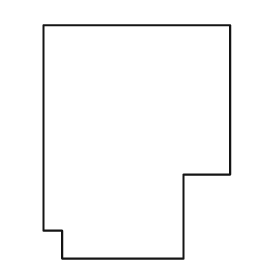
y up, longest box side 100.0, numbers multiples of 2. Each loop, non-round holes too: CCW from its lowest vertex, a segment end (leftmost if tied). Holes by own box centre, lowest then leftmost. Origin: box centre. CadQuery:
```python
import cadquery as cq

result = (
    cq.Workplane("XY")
    .moveTo(-32.0, -50.0)
    .lineTo(20.0, -50.0)
    .lineTo(20.0, -14.0)
    .lineTo(40.0, -14.0)
    .lineTo(40.0, 50.0)
    .lineTo(-40.0, 50.0)
    .lineTo(-40.0, -38.0)
    .lineTo(-32.0, -38.0)
    .close()
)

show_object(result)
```